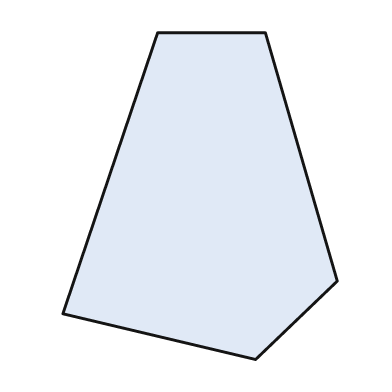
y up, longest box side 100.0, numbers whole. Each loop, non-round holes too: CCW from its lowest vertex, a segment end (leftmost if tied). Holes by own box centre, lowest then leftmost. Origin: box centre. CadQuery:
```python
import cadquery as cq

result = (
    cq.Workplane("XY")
    .moveTo(17.0, -50.0)
    .lineTo(42.0, -26.0)
    .lineTo(20.0, 50.0)
    .lineTo(-13.0, 50.0)
    .lineTo(-42.0, -36.0)
    .close()
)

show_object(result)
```